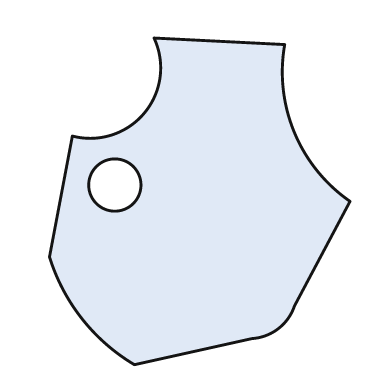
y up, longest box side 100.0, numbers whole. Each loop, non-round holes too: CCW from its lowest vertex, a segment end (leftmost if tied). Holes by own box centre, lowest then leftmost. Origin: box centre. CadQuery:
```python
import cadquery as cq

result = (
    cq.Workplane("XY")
    .moveTo(-20.0, -50.0)
    .lineTo(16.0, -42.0)
    .threePointArc((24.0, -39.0), (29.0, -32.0))
    .lineTo(46.0, 0.0)
    .threePointArc((29.0, 21.0), (26.0, 48.0))
    .lineTo(-14.0, 50.0)
    .threePointArc((-17.0, 27.0), (-39.0, 20.0))
    .lineTo(-46.0, -17.0)
    .threePointArc((-36.0, -36.0), (-20.0, -50.0))
    .close()
    .moveTo(-26.0, 5.0)
    .circle(8.0)
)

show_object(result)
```